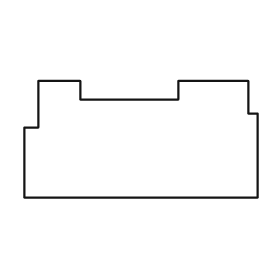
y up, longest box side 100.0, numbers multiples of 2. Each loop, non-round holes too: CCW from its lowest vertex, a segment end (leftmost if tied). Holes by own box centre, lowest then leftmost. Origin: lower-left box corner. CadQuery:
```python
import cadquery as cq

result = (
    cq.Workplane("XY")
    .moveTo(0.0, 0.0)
    .lineTo(100.0, 0.0)
    .lineTo(100.0, 36.0)
    .lineTo(96.0, 36.0)
    .lineTo(96.0, 50.0)
    .lineTo(66.0, 50.0)
    .lineTo(66.0, 42.0)
    .lineTo(24.0, 42.0)
    .lineTo(24.0, 50.0)
    .lineTo(6.0, 50.0)
    .lineTo(6.0, 30.0)
    .lineTo(0.0, 30.0)
    .close()
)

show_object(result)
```